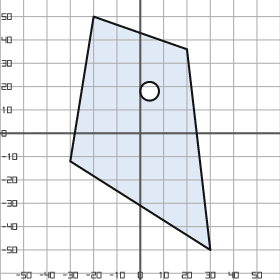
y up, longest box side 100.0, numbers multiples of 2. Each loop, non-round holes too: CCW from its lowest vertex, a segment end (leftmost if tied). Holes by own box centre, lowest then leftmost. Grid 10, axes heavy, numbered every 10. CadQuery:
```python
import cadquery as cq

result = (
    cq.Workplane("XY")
    .moveTo(30.0, -50.0)
    .lineTo(20.0, 36.0)
    .lineTo(-20.0, 50.0)
    .lineTo(-30.0, -12.0)
    .close()
    .moveTo(4.0, 18.0)
    .circle(4.0)
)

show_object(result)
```